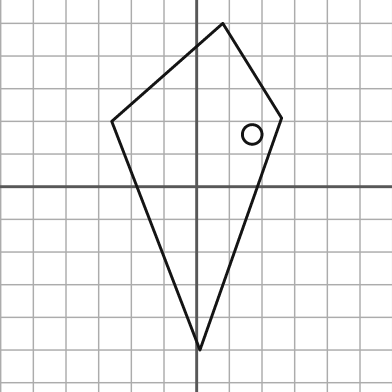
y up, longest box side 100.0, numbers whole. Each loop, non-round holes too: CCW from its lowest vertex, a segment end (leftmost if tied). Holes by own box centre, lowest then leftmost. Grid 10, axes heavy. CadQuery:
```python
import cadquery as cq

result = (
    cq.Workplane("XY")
    .moveTo(1.0, -50.0)
    .lineTo(26.0, 21.0)
    .lineTo(8.0, 50.0)
    .lineTo(-26.0, 20.0)
    .close()
    .moveTo(17.0, 16.0)
    .circle(3.0)
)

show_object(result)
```